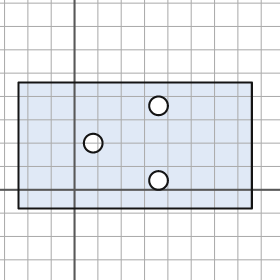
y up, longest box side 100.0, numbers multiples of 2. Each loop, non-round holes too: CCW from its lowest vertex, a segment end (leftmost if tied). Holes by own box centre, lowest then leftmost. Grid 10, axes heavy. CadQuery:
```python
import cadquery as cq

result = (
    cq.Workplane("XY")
    .moveTo(-24.0, -8.0)
    .lineTo(76.0, -8.0)
    .lineTo(76.0, 46.0)
    .lineTo(-24.0, 46.0)
    .close()
    .moveTo(36.0, 4.0)
    .circle(4.0)
    .moveTo(8.0, 20.0)
    .circle(4.0)
    .moveTo(36.0, 36.0)
    .circle(4.0)
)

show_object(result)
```